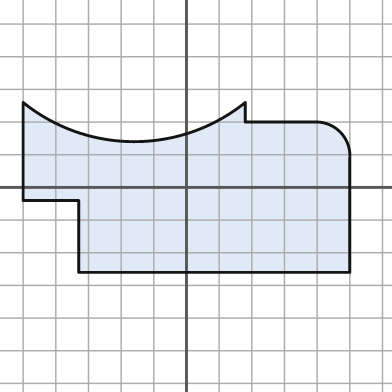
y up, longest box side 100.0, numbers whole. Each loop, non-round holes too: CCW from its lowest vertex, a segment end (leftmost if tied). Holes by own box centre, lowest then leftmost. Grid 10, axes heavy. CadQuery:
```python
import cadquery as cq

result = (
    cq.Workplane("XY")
    .moveTo(-33.0, -26.0)
    .lineTo(50.0, -26.0)
    .lineTo(50.0, 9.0)
    .threePointArc((47.0, 17.0), (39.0, 20.0))
    .lineTo(18.0, 20.0)
    .lineTo(18.0, 26.0)
    .threePointArc((-16.0, 14.0), (-50.0, 26.0))
    .lineTo(-50.0, -4.0)
    .lineTo(-33.0, -4.0)
    .close()
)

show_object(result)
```